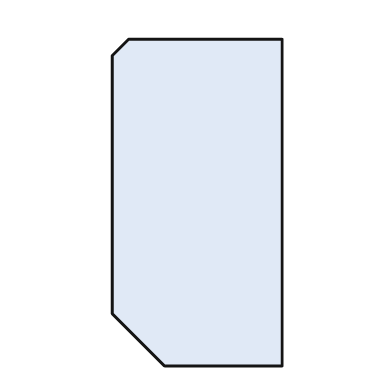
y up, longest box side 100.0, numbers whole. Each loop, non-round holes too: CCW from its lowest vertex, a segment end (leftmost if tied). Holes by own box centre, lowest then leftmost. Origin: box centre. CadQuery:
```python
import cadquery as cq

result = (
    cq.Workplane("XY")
    .moveTo(-10.0, -50.0)
    .lineTo(26.0, -50.0)
    .lineTo(26.0, 50.0)
    .lineTo(-21.0, 50.0)
    .lineTo(-26.0, 45.0)
    .lineTo(-26.0, -34.0)
    .close()
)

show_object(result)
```